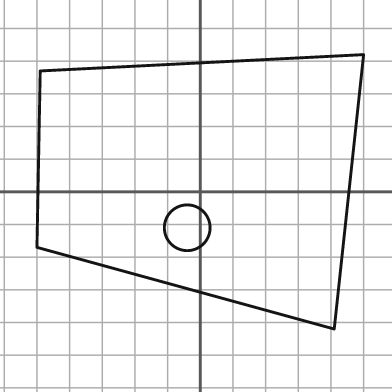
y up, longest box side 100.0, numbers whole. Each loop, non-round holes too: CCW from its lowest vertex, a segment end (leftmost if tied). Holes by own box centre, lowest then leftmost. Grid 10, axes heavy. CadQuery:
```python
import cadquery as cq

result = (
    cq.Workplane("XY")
    .moveTo(41.0, -42.0)
    .lineTo(50.0, 42.0)
    .lineTo(-49.0, 37.0)
    .lineTo(-50.0, -17.0)
    .close()
    .moveTo(-4.0, -11.0)
    .circle(7.0)
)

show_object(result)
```